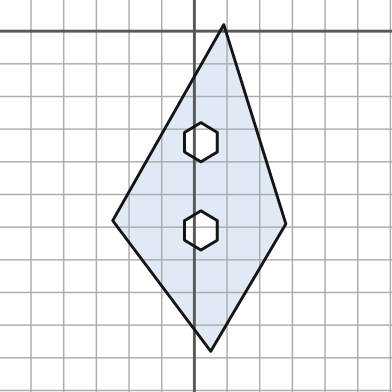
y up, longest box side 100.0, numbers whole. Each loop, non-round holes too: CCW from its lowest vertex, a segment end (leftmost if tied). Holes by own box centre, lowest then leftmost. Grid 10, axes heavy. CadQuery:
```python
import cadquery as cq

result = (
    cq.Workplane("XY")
    .moveTo(5.0, -98.0)
    .lineTo(28.0, -59.0)
    .lineTo(9.0, 2.0)
    .lineTo(-25.0, -58.0)
    .close()
    .moveTo(2.0, -67.0)
    .lineTo(7.0, -64.0)
    .lineTo(7.0, -58.0)
    .lineTo(2.0, -55.0)
    .lineTo(-3.0, -58.0)
    .lineTo(-3.0, -64.0)
    .close()
    .moveTo(2.0, -40.0)
    .lineTo(7.0, -37.0)
    .lineTo(7.0, -31.0)
    .lineTo(2.0, -28.0)
    .lineTo(-3.0, -31.0)
    .lineTo(-3.0, -37.0)
    .close()
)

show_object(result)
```